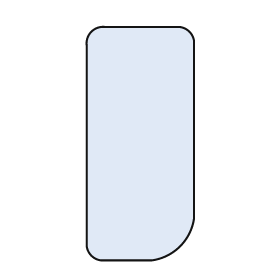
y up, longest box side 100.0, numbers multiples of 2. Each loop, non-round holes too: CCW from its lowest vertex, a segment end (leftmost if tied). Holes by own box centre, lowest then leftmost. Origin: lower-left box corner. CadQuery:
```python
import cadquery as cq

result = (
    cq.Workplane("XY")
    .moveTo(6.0, 0.0)
    .lineTo(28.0, 0.0)
    .threePointArc((40.0, 6.0), (46.0, 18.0))
    .lineTo(46.0, 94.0)
    .threePointArc((44.0, 98.0), (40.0, 100.0))
    .lineTo(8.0, 100.0)
    .threePointArc((2.0, 98.0), (0.0, 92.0))
    .lineTo(0.0, 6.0)
    .threePointArc((2.0, 2.0), (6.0, 0.0))
    .close()
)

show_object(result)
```